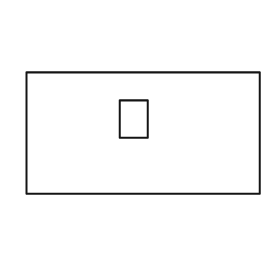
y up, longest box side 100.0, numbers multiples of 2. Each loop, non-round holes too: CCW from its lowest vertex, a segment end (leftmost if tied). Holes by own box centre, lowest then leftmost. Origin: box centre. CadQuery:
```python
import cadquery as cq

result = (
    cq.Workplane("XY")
    .moveTo(-50.0, -26.0)
    .lineTo(50.0, -26.0)
    .lineTo(50.0, 26.0)
    .lineTo(-50.0, 26.0)
    .close()
    .moveTo(-10.0, -2.0)
    .lineTo(2.0, -2.0)
    .lineTo(2.0, 14.0)
    .lineTo(-10.0, 14.0)
    .close()
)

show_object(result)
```